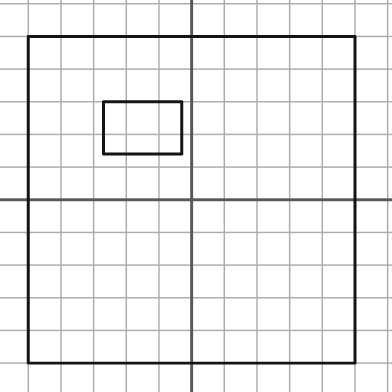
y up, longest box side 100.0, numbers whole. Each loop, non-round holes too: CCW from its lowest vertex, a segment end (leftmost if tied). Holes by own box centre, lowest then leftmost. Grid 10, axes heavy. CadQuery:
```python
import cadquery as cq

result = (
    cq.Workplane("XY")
    .moveTo(-50.0, -50.0)
    .lineTo(50.0, -50.0)
    .lineTo(50.0, 50.0)
    .lineTo(-50.0, 50.0)
    .close()
    .moveTo(-27.0, 14.0)
    .lineTo(-3.0, 14.0)
    .lineTo(-3.0, 30.0)
    .lineTo(-27.0, 30.0)
    .close()
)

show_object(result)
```